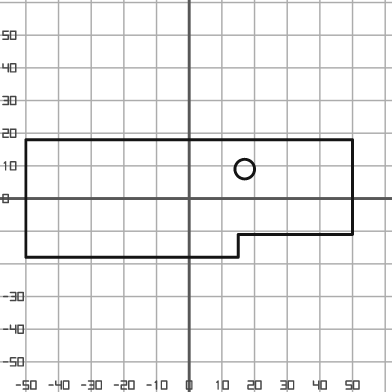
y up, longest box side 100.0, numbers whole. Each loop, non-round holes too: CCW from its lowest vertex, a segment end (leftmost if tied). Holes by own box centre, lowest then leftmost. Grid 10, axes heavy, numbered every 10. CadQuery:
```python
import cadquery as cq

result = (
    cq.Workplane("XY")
    .moveTo(-50.0, -18.0)
    .lineTo(15.0, -18.0)
    .lineTo(15.0, -11.0)
    .lineTo(50.0, -11.0)
    .lineTo(50.0, 18.0)
    .lineTo(-50.0, 18.0)
    .close()
    .moveTo(17.0, 9.0)
    .circle(3.0)
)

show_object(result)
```